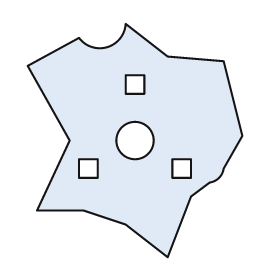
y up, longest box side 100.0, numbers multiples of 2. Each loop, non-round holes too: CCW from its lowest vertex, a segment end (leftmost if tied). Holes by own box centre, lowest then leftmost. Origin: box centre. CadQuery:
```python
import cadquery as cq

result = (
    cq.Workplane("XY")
    .moveTo(14.0, -50.0)
    .lineTo(24.0, -24.0)
    .lineTo(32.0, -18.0)
    .threePointArc((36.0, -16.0), (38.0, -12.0))
    .lineTo(46.0, 2.0)
    .lineTo(38.0, 34.0)
    .lineTo(14.0, 36.0)
    .lineTo(-4.0, 50.0)
    .threePointArc((-12.0, 40.0), (-24.0, 44.0))
    .lineTo(-46.0, 32.0)
    .lineTo(-28.0, 0.0)
    .lineTo(-42.0, -30.0)
    .lineTo(-22.0, -30.0)
    .lineTo(-4.0, -36.0)
    .close()
    .moveTo(-24.0, -16.0)
    .lineTo(-16.0, -16.0)
    .lineTo(-16.0, -8.0)
    .lineTo(-24.0, -8.0)
    .close()
    .moveTo(16.0, -16.0)
    .lineTo(24.0, -16.0)
    .lineTo(24.0, -8.0)
    .lineTo(16.0, -8.0)
    .close()
    .moveTo(0.0, 0.0)
    .circle(8.0)
    .moveTo(-4.0, 20.0)
    .lineTo(4.0, 20.0)
    .lineTo(4.0, 28.0)
    .lineTo(-4.0, 28.0)
    .close()
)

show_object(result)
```